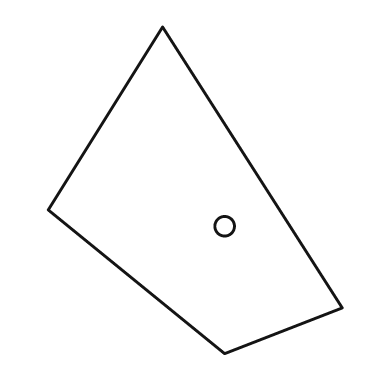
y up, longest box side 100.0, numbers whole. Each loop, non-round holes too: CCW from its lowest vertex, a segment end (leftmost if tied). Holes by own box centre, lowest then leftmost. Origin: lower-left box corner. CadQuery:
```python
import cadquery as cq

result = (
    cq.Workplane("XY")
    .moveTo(54.0, 0.0)
    .lineTo(90.0, 14.0)
    .lineTo(35.0, 100.0)
    .lineTo(0.0, 44.0)
    .close()
    .moveTo(54.0, 39.0)
    .circle(3.0)
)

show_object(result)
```